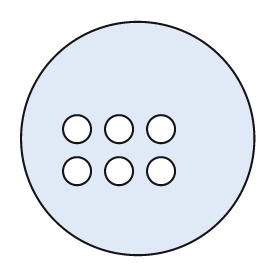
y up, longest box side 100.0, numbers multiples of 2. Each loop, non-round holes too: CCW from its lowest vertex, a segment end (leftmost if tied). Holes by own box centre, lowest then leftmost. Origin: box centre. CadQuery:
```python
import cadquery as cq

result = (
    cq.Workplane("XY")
    .moveTo(0.0, 0.0)
    .circle(50.0)
    .moveTo(-26.0, -14.0)
    .circle(6.0)
    .moveTo(-8.0, -14.0)
    .circle(6.0)
    .moveTo(10.0, -14.0)
    .circle(6.0)
    .moveTo(-26.0, 4.0)
    .circle(6.0)
    .moveTo(-8.0, 4.0)
    .circle(6.0)
    .moveTo(10.0, 4.0)
    .circle(6.0)
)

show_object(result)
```